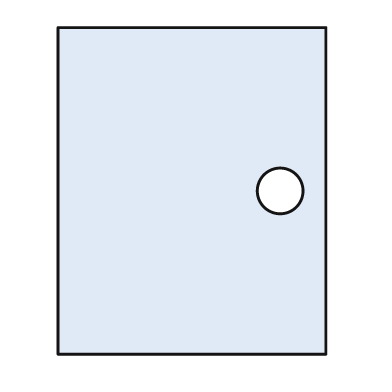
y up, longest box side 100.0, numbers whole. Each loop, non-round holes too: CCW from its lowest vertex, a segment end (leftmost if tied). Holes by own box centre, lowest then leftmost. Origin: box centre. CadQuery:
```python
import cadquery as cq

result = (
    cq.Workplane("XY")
    .moveTo(-41.0, -50.0)
    .lineTo(41.0, -50.0)
    .lineTo(41.0, 50.0)
    .lineTo(-41.0, 50.0)
    .close()
    .moveTo(27.0, 0.0)
    .circle(7.0)
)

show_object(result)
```